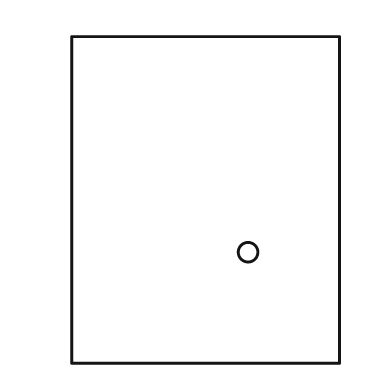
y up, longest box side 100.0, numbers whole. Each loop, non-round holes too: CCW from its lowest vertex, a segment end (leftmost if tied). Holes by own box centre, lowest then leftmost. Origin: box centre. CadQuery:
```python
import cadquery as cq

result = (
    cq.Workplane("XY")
    .moveTo(-41.0, -50.0)
    .lineTo(41.0, -50.0)
    .lineTo(41.0, 50.0)
    .lineTo(-41.0, 50.0)
    .close()
    .moveTo(13.0, -16.0)
    .circle(3.0)
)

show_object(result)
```